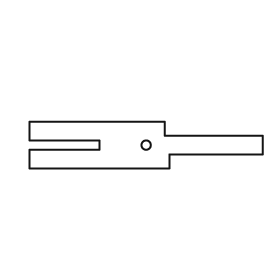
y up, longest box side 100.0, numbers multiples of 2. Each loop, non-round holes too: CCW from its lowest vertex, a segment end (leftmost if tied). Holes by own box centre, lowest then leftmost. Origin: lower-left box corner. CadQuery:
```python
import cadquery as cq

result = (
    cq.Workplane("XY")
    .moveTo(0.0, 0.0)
    .lineTo(60.0, 0.0)
    .lineTo(60.0, 6.0)
    .lineTo(100.0, 6.0)
    .lineTo(100.0, 14.0)
    .lineTo(58.0, 14.0)
    .lineTo(58.0, 20.0)
    .lineTo(0.0, 20.0)
    .lineTo(0.0, 12.0)
    .lineTo(30.0, 12.0)
    .lineTo(30.0, 8.0)
    .lineTo(0.0, 8.0)
    .close()
    .moveTo(50.0, 10.0)
    .circle(2.0)
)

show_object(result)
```